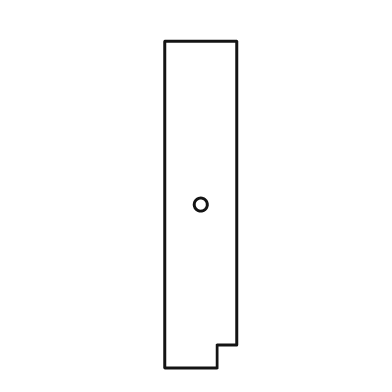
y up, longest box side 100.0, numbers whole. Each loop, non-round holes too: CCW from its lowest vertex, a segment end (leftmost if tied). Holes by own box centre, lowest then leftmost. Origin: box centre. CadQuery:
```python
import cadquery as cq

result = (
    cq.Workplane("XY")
    .moveTo(-11.0, -50.0)
    .lineTo(5.0, -50.0)
    .lineTo(5.0, -43.0)
    .lineTo(11.0, -43.0)
    .lineTo(11.0, 50.0)
    .lineTo(-11.0, 50.0)
    .close()
    .moveTo(0.0, 0.0)
    .circle(2.0)
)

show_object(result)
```